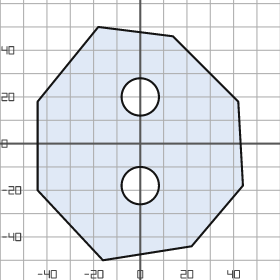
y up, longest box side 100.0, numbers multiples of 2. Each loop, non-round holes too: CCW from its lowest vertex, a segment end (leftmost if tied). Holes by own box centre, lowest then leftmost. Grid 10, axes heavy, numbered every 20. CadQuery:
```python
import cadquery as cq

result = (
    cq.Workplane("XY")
    .moveTo(-16.0, -50.0)
    .lineTo(22.0, -44.0)
    .lineTo(44.0, -18.0)
    .lineTo(42.0, 18.0)
    .lineTo(14.0, 46.0)
    .lineTo(-18.0, 50.0)
    .lineTo(-44.0, 18.0)
    .lineTo(-44.0, -20.0)
    .close()
    .moveTo(0.0, -18.0)
    .circle(8.0)
    .moveTo(0.0, 20.0)
    .circle(8.0)
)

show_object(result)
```